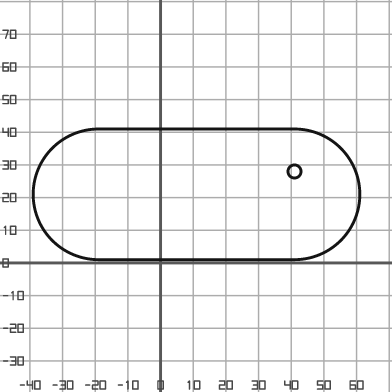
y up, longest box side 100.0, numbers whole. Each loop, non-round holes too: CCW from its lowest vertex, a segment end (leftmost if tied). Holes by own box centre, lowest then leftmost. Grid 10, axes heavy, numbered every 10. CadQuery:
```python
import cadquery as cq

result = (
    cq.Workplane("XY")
    .moveTo(-19.0, 1.0)
    .lineTo(41.0, 1.0)
    .threePointArc((61.0, 21.0), (41.0, 41.0))
    .lineTo(-19.0, 41.0)
    .threePointArc((-39.0, 21.0), (-19.0, 1.0))
    .close()
    .moveTo(41.0, 28.0)
    .circle(2.0)
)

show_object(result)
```